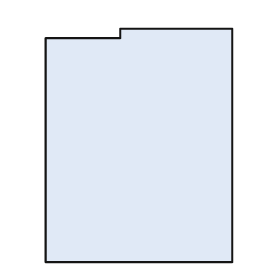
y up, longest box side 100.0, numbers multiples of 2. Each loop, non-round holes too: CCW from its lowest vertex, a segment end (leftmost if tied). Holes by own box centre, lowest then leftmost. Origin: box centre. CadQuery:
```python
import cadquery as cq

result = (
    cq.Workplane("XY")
    .moveTo(-40.0, -50.0)
    .lineTo(40.0, -50.0)
    .lineTo(40.0, 50.0)
    .lineTo(-8.0, 50.0)
    .lineTo(-8.0, 46.0)
    .lineTo(-40.0, 46.0)
    .close()
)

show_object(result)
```